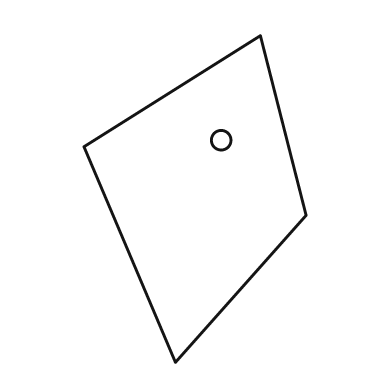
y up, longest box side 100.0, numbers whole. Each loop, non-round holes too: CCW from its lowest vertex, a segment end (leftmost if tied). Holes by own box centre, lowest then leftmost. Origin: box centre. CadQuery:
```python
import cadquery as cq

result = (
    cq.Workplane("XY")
    .moveTo(-6.0, -50.0)
    .lineTo(34.0, -5.0)
    .lineTo(20.0, 50.0)
    .lineTo(-34.0, 16.0)
    .close()
    .moveTo(8.0, 18.0)
    .circle(3.0)
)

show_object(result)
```